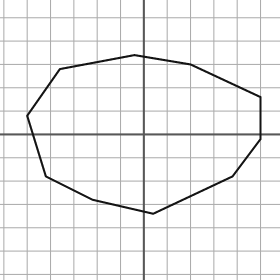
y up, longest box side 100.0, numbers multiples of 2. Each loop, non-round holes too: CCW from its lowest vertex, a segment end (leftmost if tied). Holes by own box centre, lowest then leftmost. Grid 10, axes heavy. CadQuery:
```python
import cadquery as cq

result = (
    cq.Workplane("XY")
    .moveTo(4.0, -34.0)
    .lineTo(38.0, -18.0)
    .lineTo(50.0, -2.0)
    .lineTo(50.0, 16.0)
    .lineTo(20.0, 30.0)
    .lineTo(-4.0, 34.0)
    .lineTo(-36.0, 28.0)
    .lineTo(-50.0, 8.0)
    .lineTo(-42.0, -18.0)
    .lineTo(-22.0, -28.0)
    .close()
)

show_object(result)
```